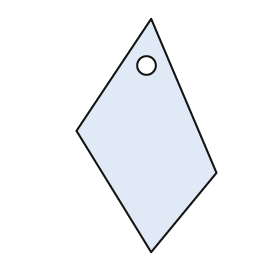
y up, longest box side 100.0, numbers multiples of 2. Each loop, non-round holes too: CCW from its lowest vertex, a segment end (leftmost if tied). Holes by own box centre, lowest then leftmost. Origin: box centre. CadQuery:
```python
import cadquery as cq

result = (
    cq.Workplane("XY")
    .moveTo(2.0, -50.0)
    .lineTo(30.0, -16.0)
    .lineTo(2.0, 50.0)
    .lineTo(-30.0, 2.0)
    .close()
    .moveTo(0.0, 30.0)
    .circle(4.0)
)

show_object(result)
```